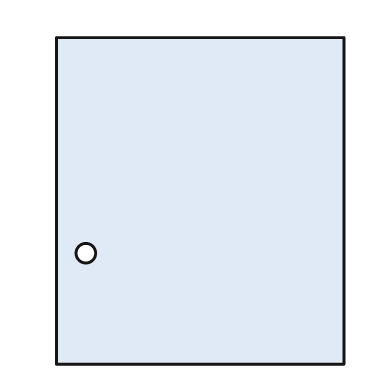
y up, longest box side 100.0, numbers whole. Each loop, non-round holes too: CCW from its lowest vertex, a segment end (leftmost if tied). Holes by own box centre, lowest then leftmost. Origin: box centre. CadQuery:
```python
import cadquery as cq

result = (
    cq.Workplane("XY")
    .moveTo(-44.0, -50.0)
    .lineTo(44.0, -50.0)
    .lineTo(44.0, 50.0)
    .lineTo(-44.0, 50.0)
    .close()
    .moveTo(-35.0, -16.0)
    .circle(3.0)
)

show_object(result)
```